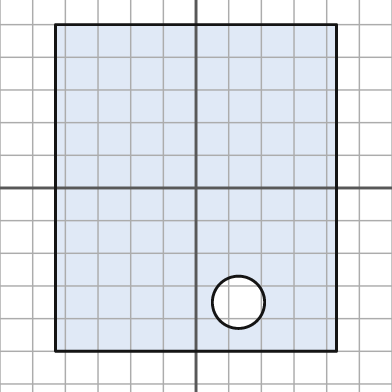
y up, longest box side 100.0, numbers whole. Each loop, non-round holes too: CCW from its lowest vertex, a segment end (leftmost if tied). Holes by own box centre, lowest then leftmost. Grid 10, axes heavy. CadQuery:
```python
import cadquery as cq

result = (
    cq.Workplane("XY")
    .moveTo(-43.0, -50.0)
    .lineTo(43.0, -50.0)
    .lineTo(43.0, 50.0)
    .lineTo(-43.0, 50.0)
    .close()
    .moveTo(13.0, -35.0)
    .circle(8.0)
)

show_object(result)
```